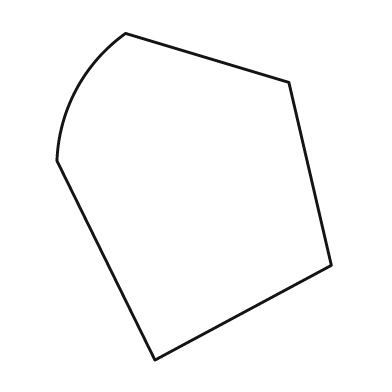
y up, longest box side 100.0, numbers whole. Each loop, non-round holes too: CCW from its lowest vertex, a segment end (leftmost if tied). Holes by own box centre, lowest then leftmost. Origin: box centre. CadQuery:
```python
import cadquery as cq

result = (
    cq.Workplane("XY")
    .moveTo(-12.0, -50.0)
    .lineTo(42.0, -21.0)
    .lineTo(29.0, 35.0)
    .lineTo(-21.0, 50.0)
    .threePointArc((-36.0, 33.0), (-42.0, 11.0))
    .close()
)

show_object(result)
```